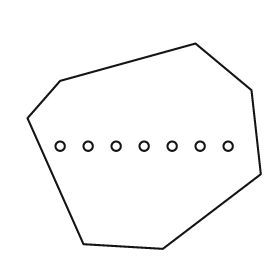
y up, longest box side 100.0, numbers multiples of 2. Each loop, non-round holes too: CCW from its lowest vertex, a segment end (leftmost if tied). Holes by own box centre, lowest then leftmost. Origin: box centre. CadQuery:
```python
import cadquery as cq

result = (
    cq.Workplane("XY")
    .moveTo(8.0, -44.0)
    .lineTo(50.0, -12.0)
    .lineTo(46.0, 24.0)
    .lineTo(22.0, 44.0)
    .lineTo(-36.0, 28.0)
    .lineTo(-50.0, 12.0)
    .lineTo(-26.0, -42.0)
    .close()
    .moveTo(-36.0, 0.0)
    .circle(2.0)
    .moveTo(-24.0, 0.0)
    .circle(2.0)
    .moveTo(-12.0, 0.0)
    .circle(2.0)
    .moveTo(0.0, 0.0)
    .circle(2.0)
    .moveTo(12.0, 0.0)
    .circle(2.0)
    .moveTo(24.0, 0.0)
    .circle(2.0)
    .moveTo(36.0, 0.0)
    .circle(2.0)
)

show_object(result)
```